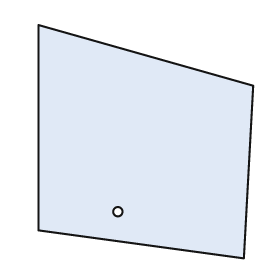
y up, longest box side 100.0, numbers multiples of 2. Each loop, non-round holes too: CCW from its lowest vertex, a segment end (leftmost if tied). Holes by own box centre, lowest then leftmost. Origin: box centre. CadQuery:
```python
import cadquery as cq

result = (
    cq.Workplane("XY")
    .moveTo(42.0, -50.0)
    .lineTo(46.0, 24.0)
    .lineTo(-46.0, 50.0)
    .lineTo(-46.0, -38.0)
    .close()
    .moveTo(-12.0, -30.0)
    .circle(2.0)
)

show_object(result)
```